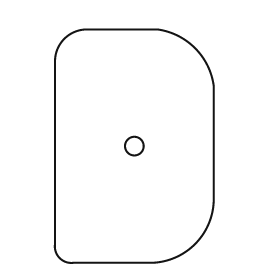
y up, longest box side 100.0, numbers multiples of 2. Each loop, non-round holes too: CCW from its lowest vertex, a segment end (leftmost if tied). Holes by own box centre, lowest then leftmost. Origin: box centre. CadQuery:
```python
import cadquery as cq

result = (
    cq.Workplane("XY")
    .moveTo(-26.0, -50.0)
    .lineTo(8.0, -50.0)
    .threePointArc((26.0, -42.0), (34.0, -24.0))
    .lineTo(34.0, 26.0)
    .threePointArc((26.0, 42.0), (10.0, 50.0))
    .lineTo(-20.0, 50.0)
    .threePointArc((-30.0, 46.0), (-34.0, 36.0))
    .lineTo(-34.0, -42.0)
    .threePointArc((-32.0, -48.0), (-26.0, -50.0))
    .close()
    .moveTo(0.0, 0.0)
    .circle(4.0)
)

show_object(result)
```